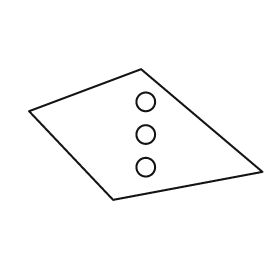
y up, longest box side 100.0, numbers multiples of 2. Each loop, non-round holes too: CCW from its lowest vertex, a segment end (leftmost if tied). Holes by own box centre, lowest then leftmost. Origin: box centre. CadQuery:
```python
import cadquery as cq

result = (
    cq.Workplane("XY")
    .moveTo(-14.0, -28.0)
    .lineTo(50.0, -16.0)
    .lineTo(-2.0, 28.0)
    .lineTo(-50.0, 10.0)
    .close()
    .moveTo(0.0, -14.0)
    .circle(4.0)
    .moveTo(0.0, 0.0)
    .circle(4.0)
    .moveTo(0.0, 14.0)
    .circle(4.0)
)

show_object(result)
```